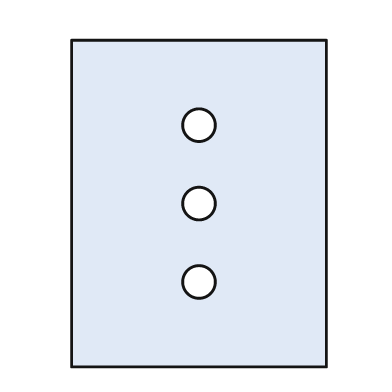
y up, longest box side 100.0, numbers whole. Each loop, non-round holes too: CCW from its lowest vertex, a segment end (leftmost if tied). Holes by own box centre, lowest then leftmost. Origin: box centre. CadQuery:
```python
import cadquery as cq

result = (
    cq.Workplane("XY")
    .moveTo(-39.0, -50.0)
    .lineTo(39.0, -50.0)
    .lineTo(39.0, 50.0)
    .lineTo(-39.0, 50.0)
    .close()
    .moveTo(0.0, -24.0)
    .circle(5.0)
    .moveTo(0.0, 0.0)
    .circle(5.0)
    .moveTo(0.0, 24.0)
    .circle(5.0)
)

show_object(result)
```